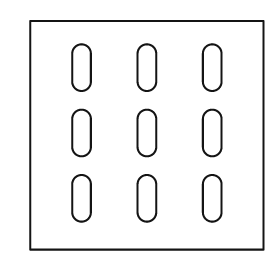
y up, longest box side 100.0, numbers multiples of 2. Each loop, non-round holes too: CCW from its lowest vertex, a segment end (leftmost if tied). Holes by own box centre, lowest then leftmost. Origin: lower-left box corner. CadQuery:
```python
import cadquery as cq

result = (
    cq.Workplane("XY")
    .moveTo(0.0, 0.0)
    .lineTo(100.0, 0.0)
    .lineTo(100.0, 98.0)
    .lineTo(0.0, 98.0)
    .close()
    .moveTo(18.0, 16.0)
    .threePointArc((22.0, 12.0), (26.0, 16.0))
    .lineTo(26.0, 28.0)
    .threePointArc((22.0, 32.0), (18.0, 28.0))
    .close()
    .moveTo(46.0, 16.0)
    .threePointArc((50.0, 12.0), (54.0, 16.0))
    .lineTo(54.0, 28.0)
    .threePointArc((50.0, 32.0), (46.0, 28.0))
    .close()
    .moveTo(74.0, 16.0)
    .threePointArc((78.0, 12.0), (82.0, 16.0))
    .lineTo(82.0, 28.0)
    .threePointArc((78.0, 32.0), (74.0, 28.0))
    .close()
    .moveTo(18.0, 44.0)
    .threePointArc((22.0, 40.0), (26.0, 44.0))
    .lineTo(26.0, 56.0)
    .threePointArc((22.0, 60.0), (18.0, 56.0))
    .close()
    .moveTo(46.0, 44.0)
    .threePointArc((50.0, 40.0), (54.0, 44.0))
    .lineTo(54.0, 56.0)
    .threePointArc((50.0, 60.0), (46.0, 56.0))
    .close()
    .moveTo(74.0, 44.0)
    .threePointArc((78.0, 40.0), (82.0, 44.0))
    .lineTo(82.0, 56.0)
    .threePointArc((78.0, 60.0), (74.0, 56.0))
    .close()
    .moveTo(18.0, 72.0)
    .threePointArc((22.0, 68.0), (26.0, 72.0))
    .lineTo(26.0, 84.0)
    .threePointArc((22.0, 88.0), (18.0, 84.0))
    .close()
    .moveTo(46.0, 72.0)
    .threePointArc((50.0, 68.0), (54.0, 72.0))
    .lineTo(54.0, 84.0)
    .threePointArc((50.0, 88.0), (46.0, 84.0))
    .close()
    .moveTo(74.0, 72.0)
    .threePointArc((78.0, 68.0), (82.0, 72.0))
    .lineTo(82.0, 84.0)
    .threePointArc((78.0, 88.0), (74.0, 84.0))
    .close()
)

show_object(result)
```